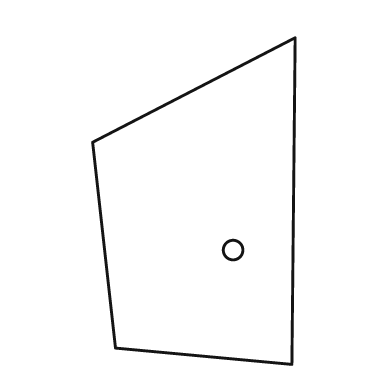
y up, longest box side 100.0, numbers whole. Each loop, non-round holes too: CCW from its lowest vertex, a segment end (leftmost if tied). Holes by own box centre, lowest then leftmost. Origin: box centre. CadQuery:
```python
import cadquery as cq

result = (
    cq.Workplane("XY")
    .moveTo(30.0, -50.0)
    .lineTo(31.0, 50.0)
    .lineTo(-31.0, 18.0)
    .lineTo(-24.0, -45.0)
    .close()
    .moveTo(12.0, -15.0)
    .circle(3.0)
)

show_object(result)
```